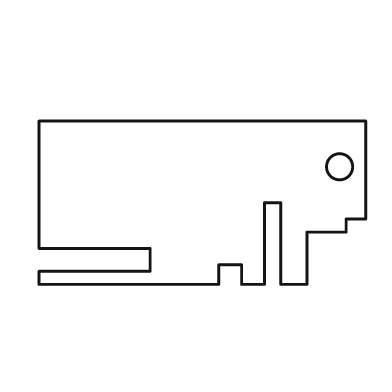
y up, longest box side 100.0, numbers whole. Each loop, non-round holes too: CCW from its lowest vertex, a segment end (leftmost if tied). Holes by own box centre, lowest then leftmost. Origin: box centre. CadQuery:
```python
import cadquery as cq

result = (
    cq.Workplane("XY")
    .moveTo(-50.0, -25.0)
    .lineTo(5.0, -25.0)
    .lineTo(5.0, -19.0)
    .lineTo(12.0, -19.0)
    .lineTo(12.0, -25.0)
    .lineTo(19.0, -25.0)
    .lineTo(19.0, 0.0)
    .lineTo(24.0, 0.0)
    .lineTo(24.0, -25.0)
    .lineTo(32.0, -25.0)
    .lineTo(32.0, -9.0)
    .lineTo(44.0, -9.0)
    .lineTo(44.0, -5.0)
    .lineTo(50.0, -5.0)
    .lineTo(50.0, 25.0)
    .lineTo(-50.0, 25.0)
    .lineTo(-50.0, -14.0)
    .lineTo(-16.0, -14.0)
    .lineTo(-16.0, -21.0)
    .lineTo(-50.0, -21.0)
    .close()
    .moveTo(42.0, 11.0)
    .circle(4.0)
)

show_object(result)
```